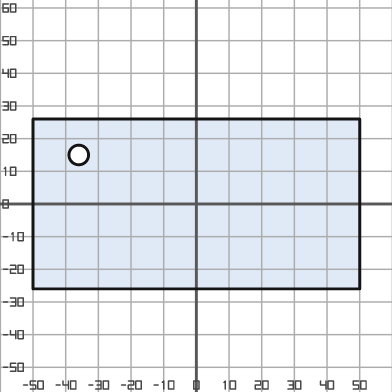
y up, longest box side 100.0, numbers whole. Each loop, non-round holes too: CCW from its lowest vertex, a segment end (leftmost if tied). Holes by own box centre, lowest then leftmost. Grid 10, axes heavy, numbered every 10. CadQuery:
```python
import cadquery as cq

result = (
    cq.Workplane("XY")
    .moveTo(-50.0, -26.0)
    .lineTo(50.0, -26.0)
    .lineTo(50.0, 26.0)
    .lineTo(-50.0, 26.0)
    .close()
    .moveTo(-36.0, 15.0)
    .circle(3.0)
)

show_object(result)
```